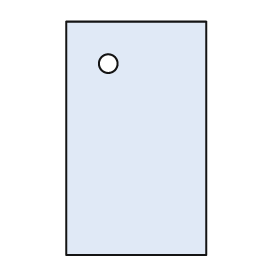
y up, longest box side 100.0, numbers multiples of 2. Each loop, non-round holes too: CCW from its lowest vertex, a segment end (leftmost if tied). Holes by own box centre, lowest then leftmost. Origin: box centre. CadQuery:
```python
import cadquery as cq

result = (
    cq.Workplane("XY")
    .moveTo(-30.0, -50.0)
    .lineTo(30.0, -50.0)
    .lineTo(30.0, 50.0)
    .lineTo(-30.0, 50.0)
    .close()
    .moveTo(-12.0, 32.0)
    .circle(4.0)
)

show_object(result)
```